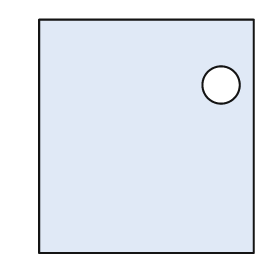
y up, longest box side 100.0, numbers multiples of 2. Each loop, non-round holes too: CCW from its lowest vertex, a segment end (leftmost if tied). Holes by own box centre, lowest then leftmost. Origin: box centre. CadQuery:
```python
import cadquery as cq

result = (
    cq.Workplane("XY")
    .moveTo(-46.0, -50.0)
    .lineTo(46.0, -50.0)
    .lineTo(46.0, 50.0)
    .lineTo(-46.0, 50.0)
    .close()
    .moveTo(32.0, 22.0)
    .circle(8.0)
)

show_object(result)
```